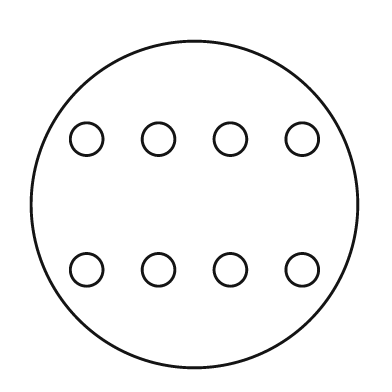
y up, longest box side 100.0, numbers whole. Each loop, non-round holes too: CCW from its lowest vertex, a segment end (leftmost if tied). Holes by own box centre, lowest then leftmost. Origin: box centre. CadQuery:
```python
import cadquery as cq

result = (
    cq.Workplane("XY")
    .moveTo(0.0, 0.0)
    .circle(50.0)
    .moveTo(-33.0, -20.0)
    .circle(5.0)
    .moveTo(-11.0, -20.0)
    .circle(5.0)
    .moveTo(11.0, -20.0)
    .circle(5.0)
    .moveTo(33.0, -20.0)
    .circle(5.0)
    .moveTo(-33.0, 20.0)
    .circle(5.0)
    .moveTo(-11.0, 20.0)
    .circle(5.0)
    .moveTo(11.0, 20.0)
    .circle(5.0)
    .moveTo(33.0, 20.0)
    .circle(5.0)
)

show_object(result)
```